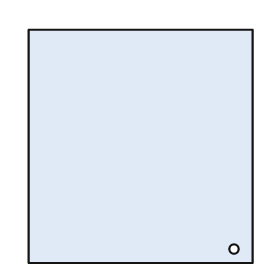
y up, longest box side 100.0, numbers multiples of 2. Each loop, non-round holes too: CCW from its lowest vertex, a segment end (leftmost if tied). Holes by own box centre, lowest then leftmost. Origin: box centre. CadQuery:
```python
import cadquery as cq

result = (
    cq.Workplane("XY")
    .moveTo(-48.0, -50.0)
    .lineTo(48.0, -50.0)
    .lineTo(48.0, 50.0)
    .lineTo(-48.0, 50.0)
    .close()
    .moveTo(40.0, -44.0)
    .circle(2.0)
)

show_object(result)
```